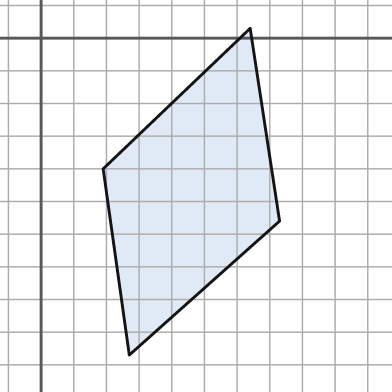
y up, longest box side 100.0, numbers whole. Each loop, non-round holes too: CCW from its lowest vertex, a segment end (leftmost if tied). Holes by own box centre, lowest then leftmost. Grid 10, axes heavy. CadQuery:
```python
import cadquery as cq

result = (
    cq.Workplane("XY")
    .moveTo(27.0, -97.0)
    .lineTo(73.0, -56.0)
    .lineTo(64.0, 3.0)
    .lineTo(19.0, -40.0)
    .close()
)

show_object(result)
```